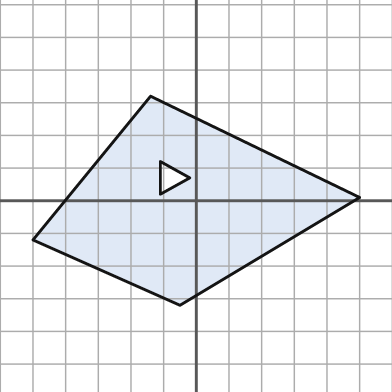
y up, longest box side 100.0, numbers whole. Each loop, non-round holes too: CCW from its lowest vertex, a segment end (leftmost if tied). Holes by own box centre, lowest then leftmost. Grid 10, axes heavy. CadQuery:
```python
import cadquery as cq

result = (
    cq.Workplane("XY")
    .moveTo(-5.0, -32.0)
    .lineTo(50.0, 1.0)
    .lineTo(-14.0, 32.0)
    .lineTo(-50.0, -12.0)
    .close()
    .moveTo(-11.0, 2.0)
    .lineTo(-2.0, 7.0)
    .lineTo(-11.0, 12.0)
    .close()
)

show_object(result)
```